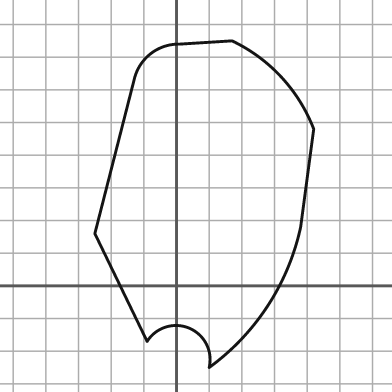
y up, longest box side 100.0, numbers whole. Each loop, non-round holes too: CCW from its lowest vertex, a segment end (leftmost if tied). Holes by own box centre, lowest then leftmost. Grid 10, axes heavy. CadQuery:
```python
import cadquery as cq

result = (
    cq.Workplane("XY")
    .moveTo(10.0, -25.0)
    .threePointArc((28.0, -6.0), (38.0, 18.0))
    .lineTo(42.0, 48.0)
    .threePointArc((32.0, 64.0), (17.0, 75.0))
    .lineTo(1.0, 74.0)
    .threePointArc((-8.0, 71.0), (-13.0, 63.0))
    .lineTo(-25.0, 16.0)
    .lineTo(-9.0, -17.0)
    .threePointArc((4.0, -13.0), (10.0, -25.0))
    .close()
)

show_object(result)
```